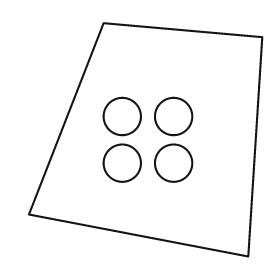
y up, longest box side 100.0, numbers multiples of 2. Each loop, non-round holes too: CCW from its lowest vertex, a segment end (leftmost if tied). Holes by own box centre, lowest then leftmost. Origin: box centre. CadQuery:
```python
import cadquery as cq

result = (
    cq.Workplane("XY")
    .moveTo(44.0, -50.0)
    .lineTo(50.0, 44.0)
    .lineTo(-18.0, 50.0)
    .lineTo(-50.0, -32.0)
    .close()
    .moveTo(-10.0, -10.0)
    .circle(8.0)
    .moveTo(12.0, -10.0)
    .circle(8.0)
    .moveTo(-10.0, 10.0)
    .circle(8.0)
    .moveTo(12.0, 10.0)
    .circle(8.0)
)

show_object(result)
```